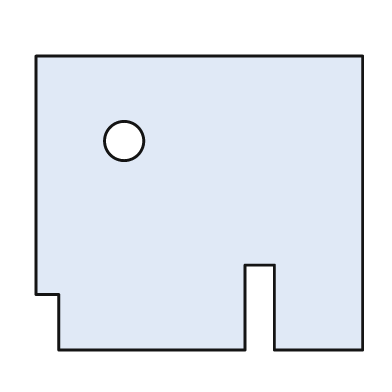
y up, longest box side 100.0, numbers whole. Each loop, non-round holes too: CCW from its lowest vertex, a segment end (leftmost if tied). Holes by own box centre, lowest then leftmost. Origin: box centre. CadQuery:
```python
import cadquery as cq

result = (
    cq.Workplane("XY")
    .moveTo(-43.0, -45.0)
    .lineTo(14.0, -45.0)
    .lineTo(14.0, -19.0)
    .lineTo(23.0, -19.0)
    .lineTo(23.0, -45.0)
    .lineTo(50.0, -45.0)
    .lineTo(50.0, 45.0)
    .lineTo(-50.0, 45.0)
    .lineTo(-50.0, -28.0)
    .lineTo(-43.0, -28.0)
    .close()
    .moveTo(-23.0, 19.0)
    .circle(6.0)
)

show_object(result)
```